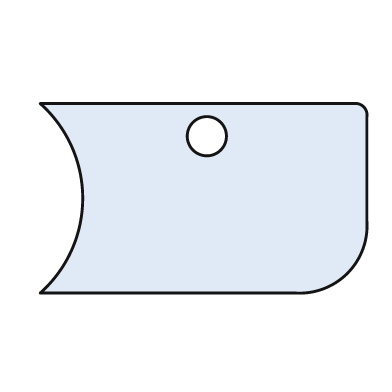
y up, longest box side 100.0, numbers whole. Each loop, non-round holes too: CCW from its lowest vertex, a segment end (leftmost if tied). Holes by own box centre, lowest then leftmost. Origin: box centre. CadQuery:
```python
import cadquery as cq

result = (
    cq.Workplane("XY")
    .moveTo(-50.0, -29.0)
    .lineTo(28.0, -29.0)
    .threePointArc((44.0, -23.0), (50.0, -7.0))
    .lineTo(50.0, 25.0)
    .threePointArc((49.0, 28.0), (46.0, 29.0))
    .lineTo(-50.0, 29.0)
    .threePointArc((-37.0, 0.0), (-50.0, -29.0))
    .close()
    .moveTo(1.0, 19.0)
    .circle(6.0)
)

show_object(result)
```